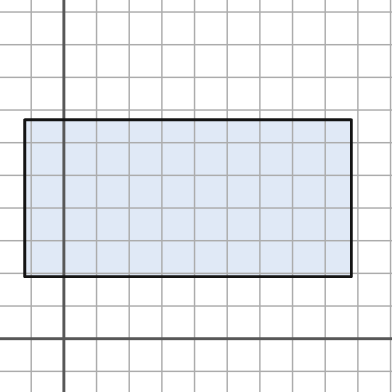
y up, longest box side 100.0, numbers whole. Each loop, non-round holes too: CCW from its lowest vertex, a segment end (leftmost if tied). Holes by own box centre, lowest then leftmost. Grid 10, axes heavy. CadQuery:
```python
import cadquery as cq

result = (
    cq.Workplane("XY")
    .moveTo(-12.0, 19.0)
    .lineTo(88.0, 19.0)
    .lineTo(88.0, 67.0)
    .lineTo(-12.0, 67.0)
    .close()
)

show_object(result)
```